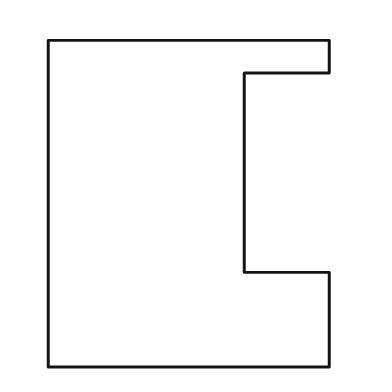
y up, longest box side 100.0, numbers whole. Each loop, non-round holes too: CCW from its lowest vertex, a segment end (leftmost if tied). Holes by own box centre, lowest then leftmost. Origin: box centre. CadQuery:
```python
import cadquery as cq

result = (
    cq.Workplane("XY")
    .moveTo(-43.0, -50.0)
    .lineTo(43.0, -50.0)
    .lineTo(43.0, -21.0)
    .lineTo(17.0, -21.0)
    .lineTo(17.0, 40.0)
    .lineTo(43.0, 40.0)
    .lineTo(43.0, 50.0)
    .lineTo(-43.0, 50.0)
    .close()
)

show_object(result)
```